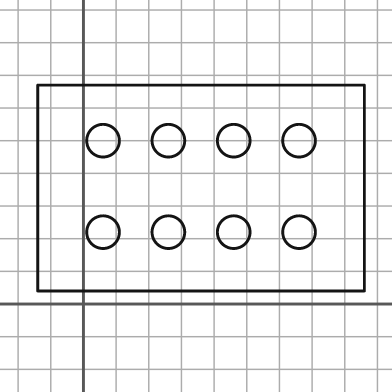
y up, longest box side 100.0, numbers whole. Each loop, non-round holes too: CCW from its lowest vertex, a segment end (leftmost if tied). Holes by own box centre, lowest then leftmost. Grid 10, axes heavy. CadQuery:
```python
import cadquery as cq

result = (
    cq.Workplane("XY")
    .moveTo(-14.0, 4.0)
    .lineTo(86.0, 4.0)
    .lineTo(86.0, 67.0)
    .lineTo(-14.0, 67.0)
    .close()
    .moveTo(6.0, 22.0)
    .circle(5.0)
    .moveTo(26.0, 22.0)
    .circle(5.0)
    .moveTo(46.0, 22.0)
    .circle(5.0)
    .moveTo(66.0, 22.0)
    .circle(5.0)
    .moveTo(6.0, 50.0)
    .circle(5.0)
    .moveTo(26.0, 50.0)
    .circle(5.0)
    .moveTo(46.0, 50.0)
    .circle(5.0)
    .moveTo(66.0, 50.0)
    .circle(5.0)
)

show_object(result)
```